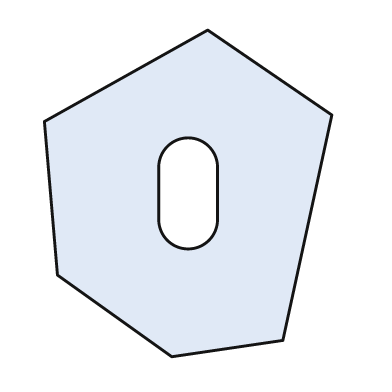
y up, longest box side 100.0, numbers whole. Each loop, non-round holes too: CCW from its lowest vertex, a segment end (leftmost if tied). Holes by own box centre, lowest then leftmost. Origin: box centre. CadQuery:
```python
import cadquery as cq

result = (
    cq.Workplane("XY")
    .moveTo(-5.0, -50.0)
    .lineTo(29.0, -45.0)
    .lineTo(44.0, 24.0)
    .lineTo(6.0, 50.0)
    .lineTo(-44.0, 22.0)
    .lineTo(-40.0, -25.0)
    .close()
    .moveTo(-9.0, -8.0)
    .threePointArc((0.0, -17.0), (9.0, -8.0))
    .lineTo(9.0, 8.0)
    .threePointArc((0.0, 17.0), (-9.0, 8.0))
    .close()
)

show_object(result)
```